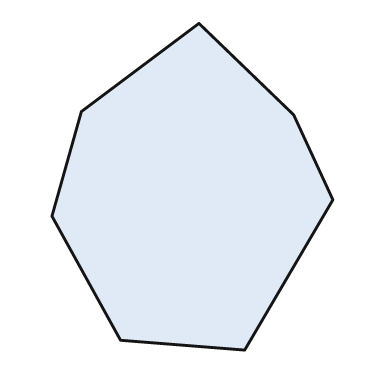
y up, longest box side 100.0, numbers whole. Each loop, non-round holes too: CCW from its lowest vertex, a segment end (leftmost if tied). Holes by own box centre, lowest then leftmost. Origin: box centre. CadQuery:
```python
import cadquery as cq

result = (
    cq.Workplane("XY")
    .moveTo(16.0, -50.0)
    .lineTo(43.0, -4.0)
    .lineTo(31.0, 22.0)
    .lineTo(2.0, 50.0)
    .lineTo(-34.0, 23.0)
    .lineTo(-43.0, -9.0)
    .lineTo(-22.0, -47.0)
    .close()
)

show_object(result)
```